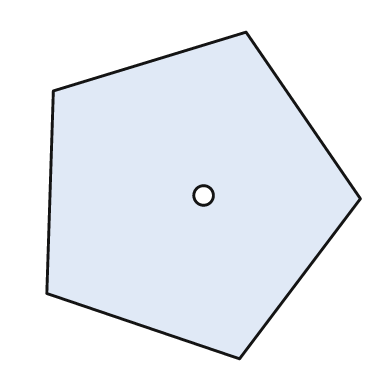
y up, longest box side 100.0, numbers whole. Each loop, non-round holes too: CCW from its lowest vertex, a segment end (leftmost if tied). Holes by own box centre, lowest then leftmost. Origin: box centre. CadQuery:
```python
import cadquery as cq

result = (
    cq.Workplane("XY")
    .moveTo(11.0, -50.0)
    .lineTo(48.0, -1.0)
    .lineTo(13.0, 50.0)
    .lineTo(-46.0, 32.0)
    .lineTo(-48.0, -30.0)
    .close()
    .moveTo(0.0, 0.0)
    .circle(3.0)
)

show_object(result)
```